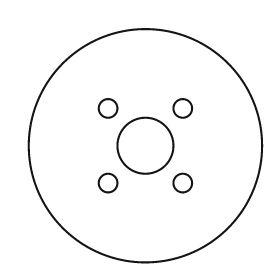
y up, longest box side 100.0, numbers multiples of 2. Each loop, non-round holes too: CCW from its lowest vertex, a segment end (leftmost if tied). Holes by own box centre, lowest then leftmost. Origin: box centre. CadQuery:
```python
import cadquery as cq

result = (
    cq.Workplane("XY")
    .moveTo(0.0, 0.0)
    .circle(50.0)
    .moveTo(-16.0, -16.0)
    .circle(4.0)
    .moveTo(16.0, -16.0)
    .circle(4.0)
    .moveTo(0.0, 0.0)
    .circle(12.0)
    .moveTo(-16.0, 16.0)
    .circle(4.0)
    .moveTo(16.0, 16.0)
    .circle(4.0)
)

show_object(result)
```